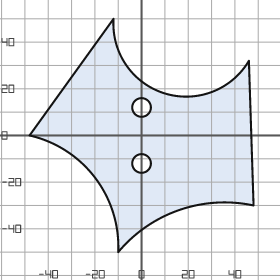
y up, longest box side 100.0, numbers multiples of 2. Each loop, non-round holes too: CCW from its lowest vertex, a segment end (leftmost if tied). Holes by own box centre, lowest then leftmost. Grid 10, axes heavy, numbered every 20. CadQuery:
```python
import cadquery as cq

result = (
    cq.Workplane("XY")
    .moveTo(-10.0, -50.0)
    .threePointArc((16.0, -32.0), (48.0, -30.0))
    .lineTo(46.0, 32.0)
    .threePointArc((10.0, 18.0), (-12.0, 50.0))
    .lineTo(-48.0, 0.0)
    .threePointArc((-20.0, -18.0), (-10.0, -50.0))
    .close()
    .moveTo(0.0, -12.0)
    .circle(4.0)
    .moveTo(0.0, 12.0)
    .circle(4.0)
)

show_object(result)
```